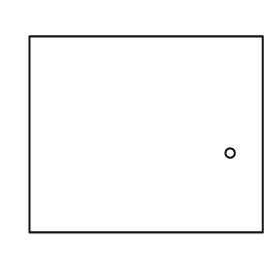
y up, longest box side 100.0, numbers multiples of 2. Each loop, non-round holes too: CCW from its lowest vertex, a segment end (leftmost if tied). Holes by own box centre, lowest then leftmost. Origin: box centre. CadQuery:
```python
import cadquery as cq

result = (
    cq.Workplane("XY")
    .moveTo(-50.0, -42.0)
    .lineTo(50.0, -42.0)
    .lineTo(50.0, 42.0)
    .lineTo(-50.0, 42.0)
    .close()
    .moveTo(36.0, -8.0)
    .circle(2.0)
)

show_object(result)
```